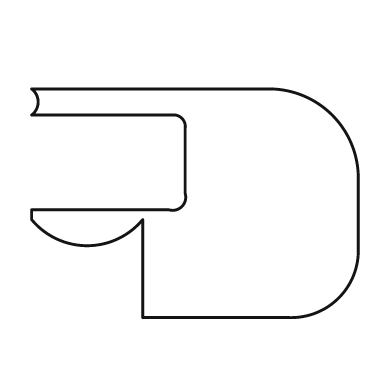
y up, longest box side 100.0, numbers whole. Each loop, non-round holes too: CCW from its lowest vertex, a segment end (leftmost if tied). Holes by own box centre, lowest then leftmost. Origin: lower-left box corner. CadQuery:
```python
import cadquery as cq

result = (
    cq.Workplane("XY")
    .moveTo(34.0, 0.0)
    .lineTo(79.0, 0.0)
    .threePointArc((94.0, 6.0), (100.0, 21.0))
    .lineTo(100.0, 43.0)
    .threePointArc((92.0, 62.0), (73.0, 70.0))
    .lineTo(0.0, 70.0)
    .threePointArc((2.0, 66.0), (0.0, 62.0))
    .lineTo(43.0, 62.0)
    .threePointArc((46.0, 61.0), (47.0, 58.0))
    .lineTo(47.0, 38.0)
    .threePointArc((46.0, 34.0), (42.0, 33.0))
    .lineTo(0.0, 33.0)
    .lineTo(0.0, 30.0)
    .threePointArc((17.0, 22.0), (34.0, 30.0))
    .close()
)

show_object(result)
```